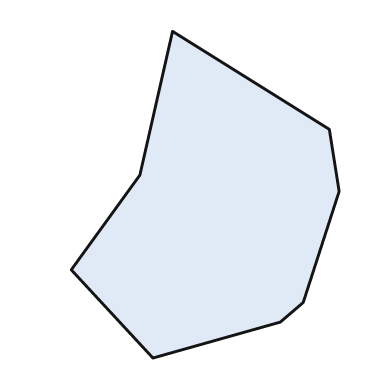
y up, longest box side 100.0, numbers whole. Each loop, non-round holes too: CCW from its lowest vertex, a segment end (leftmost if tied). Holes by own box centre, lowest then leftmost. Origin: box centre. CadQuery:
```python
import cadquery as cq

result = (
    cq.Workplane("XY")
    .moveTo(-16.0, -50.0)
    .lineTo(23.0, -39.0)
    .lineTo(30.0, -33.0)
    .lineTo(41.0, 1.0)
    .lineTo(38.0, 20.0)
    .lineTo(-10.0, 50.0)
    .lineTo(-20.0, 6.0)
    .lineTo(-41.0, -23.0)
    .close()
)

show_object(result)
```